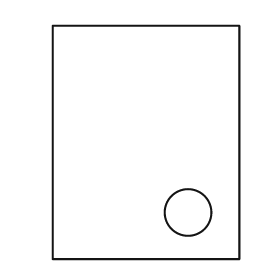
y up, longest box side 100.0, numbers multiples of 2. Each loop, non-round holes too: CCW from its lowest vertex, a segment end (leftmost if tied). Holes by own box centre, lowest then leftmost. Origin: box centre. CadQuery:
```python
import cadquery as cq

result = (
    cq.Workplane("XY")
    .moveTo(-40.0, -50.0)
    .lineTo(40.0, -50.0)
    .lineTo(40.0, 50.0)
    .lineTo(-40.0, 50.0)
    .close()
    .moveTo(18.0, -30.0)
    .circle(10.0)
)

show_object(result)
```